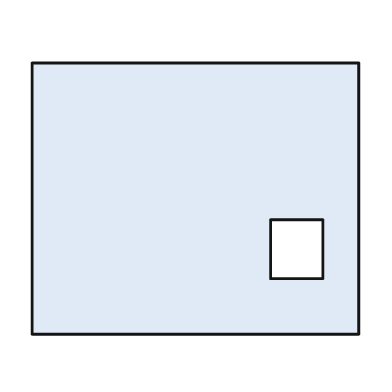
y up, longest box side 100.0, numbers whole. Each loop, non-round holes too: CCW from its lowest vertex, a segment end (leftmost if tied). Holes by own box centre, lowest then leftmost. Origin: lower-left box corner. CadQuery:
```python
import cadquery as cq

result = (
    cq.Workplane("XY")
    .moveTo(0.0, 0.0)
    .lineTo(100.0, 0.0)
    .lineTo(100.0, 83.0)
    .lineTo(0.0, 83.0)
    .close()
    .moveTo(73.0, 17.0)
    .lineTo(89.0, 17.0)
    .lineTo(89.0, 35.0)
    .lineTo(73.0, 35.0)
    .close()
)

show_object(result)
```